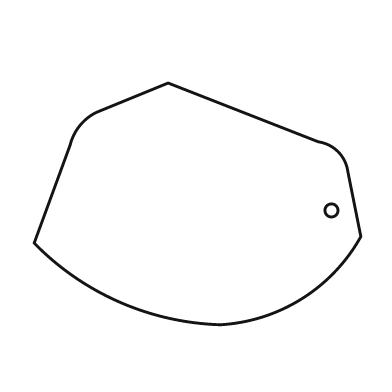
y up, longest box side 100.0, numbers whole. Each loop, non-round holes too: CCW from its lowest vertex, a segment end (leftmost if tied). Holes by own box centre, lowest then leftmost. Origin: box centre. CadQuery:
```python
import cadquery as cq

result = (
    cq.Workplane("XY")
    .moveTo(7.0, -37.0)
    .threePointArc((32.0, -29.0), (50.0, -10.0))
    .lineTo(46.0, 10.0)
    .threePointArc((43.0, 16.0), (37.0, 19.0))
    .lineTo(-9.0, 37.0)
    .lineTo(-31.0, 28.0)
    .threePointArc((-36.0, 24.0), (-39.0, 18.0))
    .lineTo(-50.0, -12.0)
    .threePointArc((-24.0, -30.0), (7.0, -37.0))
    .close()
    .moveTo(41.0, -2.0)
    .circle(2.0)
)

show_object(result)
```